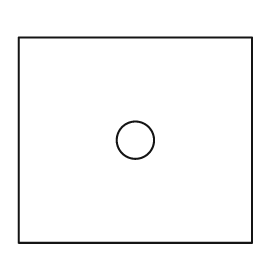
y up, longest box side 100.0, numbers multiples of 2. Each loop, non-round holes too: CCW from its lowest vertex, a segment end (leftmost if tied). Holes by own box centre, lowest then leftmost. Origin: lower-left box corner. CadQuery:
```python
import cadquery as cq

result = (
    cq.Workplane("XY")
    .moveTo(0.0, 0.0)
    .lineTo(100.0, 0.0)
    .lineTo(100.0, 88.0)
    .lineTo(0.0, 88.0)
    .close()
    .moveTo(50.0, 44.0)
    .circle(8.0)
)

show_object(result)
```